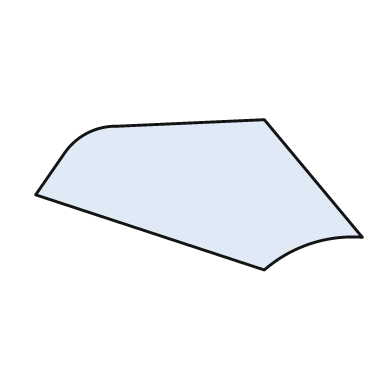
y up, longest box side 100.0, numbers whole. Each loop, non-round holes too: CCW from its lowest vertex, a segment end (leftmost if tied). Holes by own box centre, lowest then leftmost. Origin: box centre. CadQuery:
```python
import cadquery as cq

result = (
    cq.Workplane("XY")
    .moveTo(20.0, -23.0)
    .threePointArc((34.0, -15.0), (50.0, -13.0))
    .lineTo(20.0, 23.0)
    .lineTo(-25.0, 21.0)
    .threePointArc((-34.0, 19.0), (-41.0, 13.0))
    .lineTo(-50.0, 0.0)
    .close()
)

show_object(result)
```